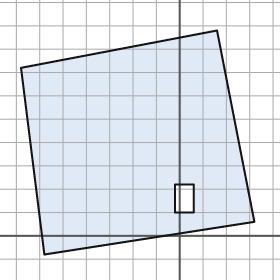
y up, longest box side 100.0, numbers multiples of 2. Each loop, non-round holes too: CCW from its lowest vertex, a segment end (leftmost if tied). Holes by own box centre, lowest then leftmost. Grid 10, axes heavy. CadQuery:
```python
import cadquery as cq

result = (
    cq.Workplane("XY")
    .moveTo(-58.0, -8.0)
    .lineTo(32.0, 6.0)
    .lineTo(16.0, 88.0)
    .lineTo(-68.0, 72.0)
    .close()
    .moveTo(-2.0, 10.0)
    .lineTo(6.0, 10.0)
    .lineTo(6.0, 22.0)
    .lineTo(-2.0, 22.0)
    .close()
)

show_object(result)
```